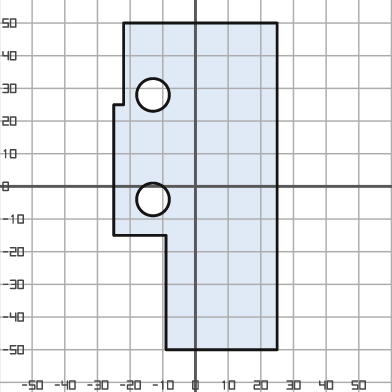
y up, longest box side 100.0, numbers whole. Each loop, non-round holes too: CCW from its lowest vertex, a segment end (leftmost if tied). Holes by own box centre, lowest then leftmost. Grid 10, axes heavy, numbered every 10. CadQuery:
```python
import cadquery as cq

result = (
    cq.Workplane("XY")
    .moveTo(-9.0, -50.0)
    .lineTo(25.0, -50.0)
    .lineTo(25.0, 50.0)
    .lineTo(-22.0, 50.0)
    .lineTo(-22.0, 25.0)
    .lineTo(-25.0, 25.0)
    .lineTo(-25.0, -15.0)
    .lineTo(-9.0, -15.0)
    .close()
    .moveTo(-13.0, -4.0)
    .circle(5.0)
    .moveTo(-13.0, 28.0)
    .circle(5.0)
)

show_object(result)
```